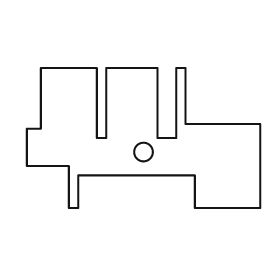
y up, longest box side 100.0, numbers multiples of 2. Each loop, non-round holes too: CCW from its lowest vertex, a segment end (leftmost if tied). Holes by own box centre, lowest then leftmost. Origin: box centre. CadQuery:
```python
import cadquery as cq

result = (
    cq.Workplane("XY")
    .moveTo(-32.0, -30.0)
    .lineTo(-28.0, -30.0)
    .lineTo(-28.0, -16.0)
    .lineTo(22.0, -16.0)
    .lineTo(22.0, -30.0)
    .lineTo(50.0, -30.0)
    .lineTo(50.0, 6.0)
    .lineTo(18.0, 6.0)
    .lineTo(18.0, 30.0)
    .lineTo(14.0, 30.0)
    .lineTo(14.0, 0.0)
    .lineTo(6.0, 0.0)
    .lineTo(6.0, 30.0)
    .lineTo(-16.0, 30.0)
    .lineTo(-16.0, 0.0)
    .lineTo(-20.0, 0.0)
    .lineTo(-20.0, 30.0)
    .lineTo(-44.0, 30.0)
    .lineTo(-44.0, 4.0)
    .lineTo(-50.0, 4.0)
    .lineTo(-50.0, -12.0)
    .lineTo(-32.0, -12.0)
    .close()
    .moveTo(0.0, -6.0)
    .circle(4.0)
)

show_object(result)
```